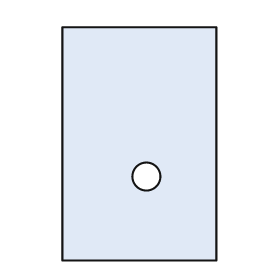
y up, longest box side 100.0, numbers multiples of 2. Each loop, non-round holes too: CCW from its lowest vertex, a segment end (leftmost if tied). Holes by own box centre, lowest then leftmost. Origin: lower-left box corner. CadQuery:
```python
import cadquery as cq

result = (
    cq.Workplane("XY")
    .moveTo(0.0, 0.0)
    .lineTo(66.0, 0.0)
    .lineTo(66.0, 100.0)
    .lineTo(0.0, 100.0)
    .close()
    .moveTo(36.0, 36.0)
    .circle(6.0)
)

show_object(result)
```